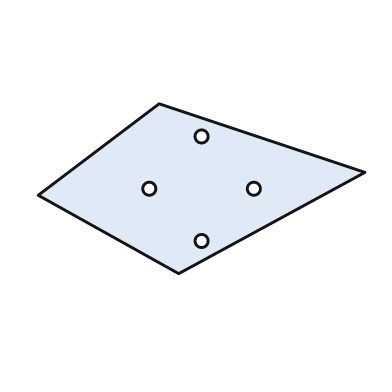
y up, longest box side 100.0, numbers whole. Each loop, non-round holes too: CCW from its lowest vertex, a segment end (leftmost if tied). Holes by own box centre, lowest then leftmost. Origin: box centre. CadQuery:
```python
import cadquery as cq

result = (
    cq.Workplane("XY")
    .moveTo(-7.0, -26.0)
    .lineTo(50.0, 5.0)
    .lineTo(-13.0, 26.0)
    .lineTo(-50.0, -2.0)
    .close()
    .moveTo(0.0, -16.0)
    .circle(2.0)
    .moveTo(-16.0, 0.0)
    .circle(2.0)
    .moveTo(16.0, 0.0)
    .circle(2.0)
    .moveTo(0.0, 16.0)
    .circle(2.0)
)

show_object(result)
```